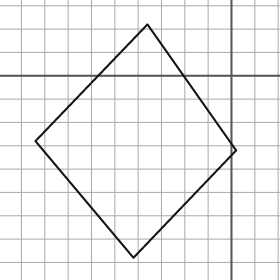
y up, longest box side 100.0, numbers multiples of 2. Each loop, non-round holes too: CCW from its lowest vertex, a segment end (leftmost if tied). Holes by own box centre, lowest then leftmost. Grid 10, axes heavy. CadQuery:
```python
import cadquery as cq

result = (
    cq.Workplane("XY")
    .moveTo(-42.0, -78.0)
    .lineTo(2.0, -32.0)
    .lineTo(-36.0, 22.0)
    .lineTo(-84.0, -28.0)
    .close()
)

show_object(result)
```